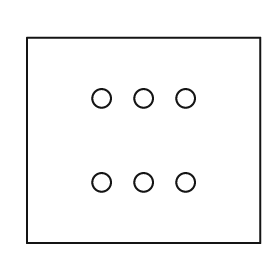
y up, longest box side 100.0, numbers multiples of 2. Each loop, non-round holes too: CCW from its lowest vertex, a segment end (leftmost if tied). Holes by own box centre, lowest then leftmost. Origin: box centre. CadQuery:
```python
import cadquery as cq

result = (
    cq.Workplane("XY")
    .moveTo(-50.0, -44.0)
    .lineTo(50.0, -44.0)
    .lineTo(50.0, 44.0)
    .lineTo(-50.0, 44.0)
    .close()
    .moveTo(-18.0, -18.0)
    .circle(4.0)
    .moveTo(0.0, -18.0)
    .circle(4.0)
    .moveTo(18.0, -18.0)
    .circle(4.0)
    .moveTo(-18.0, 18.0)
    .circle(4.0)
    .moveTo(0.0, 18.0)
    .circle(4.0)
    .moveTo(18.0, 18.0)
    .circle(4.0)
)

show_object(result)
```